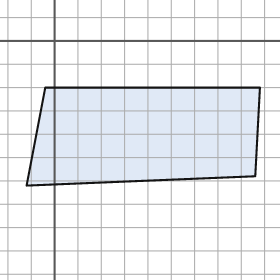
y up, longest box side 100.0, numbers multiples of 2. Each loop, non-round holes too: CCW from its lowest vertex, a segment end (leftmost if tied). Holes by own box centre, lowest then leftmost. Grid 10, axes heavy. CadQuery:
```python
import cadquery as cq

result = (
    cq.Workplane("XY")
    .moveTo(-12.0, -62.0)
    .lineTo(86.0, -58.0)
    .lineTo(88.0, -20.0)
    .lineTo(-4.0, -20.0)
    .close()
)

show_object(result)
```